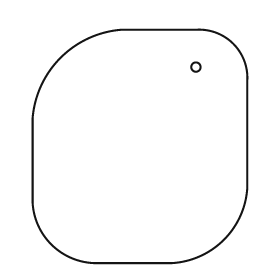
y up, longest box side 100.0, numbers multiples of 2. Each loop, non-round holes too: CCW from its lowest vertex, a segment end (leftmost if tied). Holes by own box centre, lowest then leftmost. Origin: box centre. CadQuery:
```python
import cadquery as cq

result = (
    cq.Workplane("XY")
    .moveTo(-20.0, -50.0)
    .lineTo(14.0, -50.0)
    .threePointArc((36.0, -40.0), (46.0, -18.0))
    .lineTo(46.0, 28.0)
    .threePointArc((40.0, 44.0), (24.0, 50.0))
    .lineTo(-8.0, 50.0)
    .threePointArc((-34.0, 38.0), (-46.0, 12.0))
    .lineTo(-46.0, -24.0)
    .threePointArc((-38.0, -42.0), (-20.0, -50.0))
    .close()
    .moveTo(24.0, 34.0)
    .circle(2.0)
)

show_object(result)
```